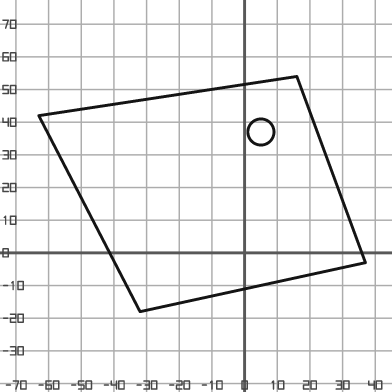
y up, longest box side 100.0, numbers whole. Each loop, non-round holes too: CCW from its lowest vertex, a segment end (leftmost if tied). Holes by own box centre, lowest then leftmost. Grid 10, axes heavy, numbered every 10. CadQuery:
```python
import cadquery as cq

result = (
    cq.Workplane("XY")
    .moveTo(-32.0, -18.0)
    .lineTo(37.0, -3.0)
    .lineTo(16.0, 54.0)
    .lineTo(-63.0, 42.0)
    .close()
    .moveTo(5.0, 37.0)
    .circle(4.0)
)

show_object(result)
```